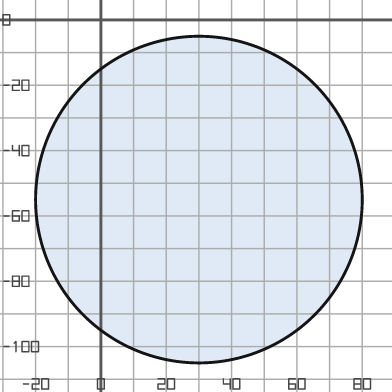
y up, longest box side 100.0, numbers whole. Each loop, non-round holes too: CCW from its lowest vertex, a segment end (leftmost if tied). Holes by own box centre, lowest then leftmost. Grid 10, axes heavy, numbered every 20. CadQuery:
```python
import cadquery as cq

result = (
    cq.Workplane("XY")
    .moveTo(30.0, -55.0)
    .circle(50.0)
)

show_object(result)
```